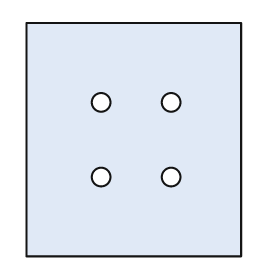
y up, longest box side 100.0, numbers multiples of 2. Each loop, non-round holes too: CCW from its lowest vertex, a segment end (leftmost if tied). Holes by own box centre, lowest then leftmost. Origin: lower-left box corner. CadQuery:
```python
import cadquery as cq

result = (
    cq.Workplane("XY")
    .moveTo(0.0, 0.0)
    .lineTo(92.0, 0.0)
    .lineTo(92.0, 100.0)
    .lineTo(0.0, 100.0)
    .close()
    .moveTo(32.0, 34.0)
    .circle(4.0)
    .moveTo(62.0, 34.0)
    .circle(4.0)
    .moveTo(32.0, 66.0)
    .circle(4.0)
    .moveTo(62.0, 66.0)
    .circle(4.0)
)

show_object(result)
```